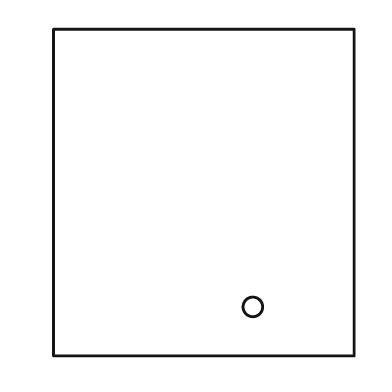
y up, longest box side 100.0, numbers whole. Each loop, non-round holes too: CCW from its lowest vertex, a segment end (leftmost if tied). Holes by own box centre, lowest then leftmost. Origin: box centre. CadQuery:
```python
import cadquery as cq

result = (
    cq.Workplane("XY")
    .moveTo(-46.0, -50.0)
    .lineTo(46.0, -50.0)
    .lineTo(46.0, 50.0)
    .lineTo(-46.0, 50.0)
    .close()
    .moveTo(15.0, -35.0)
    .circle(3.0)
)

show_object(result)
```